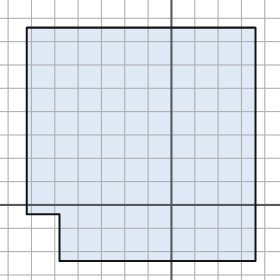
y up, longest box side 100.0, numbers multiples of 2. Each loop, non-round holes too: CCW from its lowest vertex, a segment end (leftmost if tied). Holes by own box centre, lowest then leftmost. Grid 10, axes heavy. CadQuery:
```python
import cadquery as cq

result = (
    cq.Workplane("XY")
    .moveTo(-48.0, -24.0)
    .lineTo(36.0, -24.0)
    .lineTo(36.0, 76.0)
    .lineTo(-62.0, 76.0)
    .lineTo(-62.0, -4.0)
    .lineTo(-48.0, -4.0)
    .close()
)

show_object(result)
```